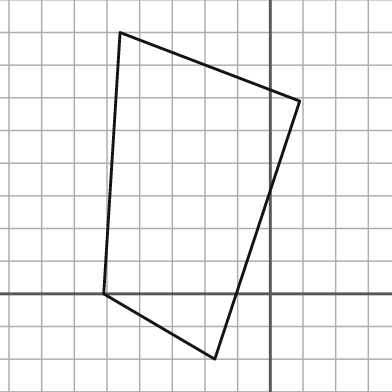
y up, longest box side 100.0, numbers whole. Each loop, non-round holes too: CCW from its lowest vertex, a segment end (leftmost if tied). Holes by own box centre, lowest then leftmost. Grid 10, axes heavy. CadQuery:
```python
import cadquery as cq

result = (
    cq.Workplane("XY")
    .moveTo(-17.0, -20.0)
    .lineTo(9.0, 59.0)
    .lineTo(-46.0, 80.0)
    .lineTo(-51.0, 0.0)
    .close()
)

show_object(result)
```